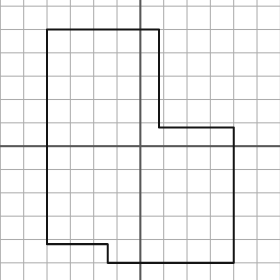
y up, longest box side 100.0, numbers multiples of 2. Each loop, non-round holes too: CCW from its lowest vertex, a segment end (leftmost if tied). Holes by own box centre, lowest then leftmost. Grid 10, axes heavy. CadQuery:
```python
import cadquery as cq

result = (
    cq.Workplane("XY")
    .moveTo(-14.0, -50.0)
    .lineTo(40.0, -50.0)
    .lineTo(40.0, 8.0)
    .lineTo(8.0, 8.0)
    .lineTo(8.0, 50.0)
    .lineTo(-40.0, 50.0)
    .lineTo(-40.0, -42.0)
    .lineTo(-14.0, -42.0)
    .close()
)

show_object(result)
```